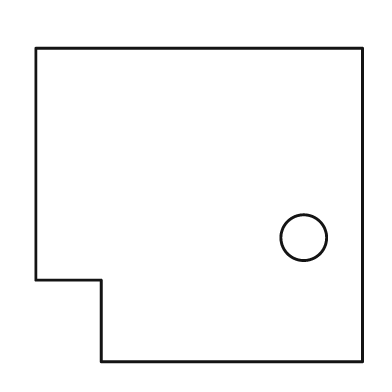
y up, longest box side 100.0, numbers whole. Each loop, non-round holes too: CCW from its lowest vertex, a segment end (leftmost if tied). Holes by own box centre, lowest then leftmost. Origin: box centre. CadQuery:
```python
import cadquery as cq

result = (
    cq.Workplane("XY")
    .moveTo(-30.0, -48.0)
    .lineTo(50.0, -48.0)
    .lineTo(50.0, 48.0)
    .lineTo(-50.0, 48.0)
    .lineTo(-50.0, -23.0)
    .lineTo(-30.0, -23.0)
    .close()
    .moveTo(32.0, -10.0)
    .circle(7.0)
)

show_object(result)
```